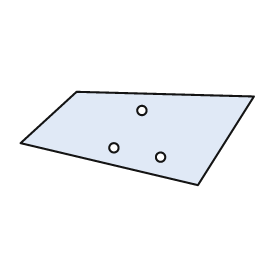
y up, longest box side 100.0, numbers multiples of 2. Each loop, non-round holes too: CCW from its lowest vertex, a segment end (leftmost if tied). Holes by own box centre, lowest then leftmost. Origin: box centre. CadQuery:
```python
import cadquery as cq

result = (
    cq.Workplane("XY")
    .moveTo(26.0, -20.0)
    .lineTo(50.0, 18.0)
    .lineTo(-26.0, 20.0)
    .lineTo(-50.0, -2.0)
    .close()
    .moveTo(10.0, -8.0)
    .circle(2.0)
    .moveTo(-10.0, -4.0)
    .circle(2.0)
    .moveTo(2.0, 12.0)
    .circle(2.0)
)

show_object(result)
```